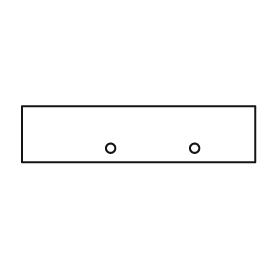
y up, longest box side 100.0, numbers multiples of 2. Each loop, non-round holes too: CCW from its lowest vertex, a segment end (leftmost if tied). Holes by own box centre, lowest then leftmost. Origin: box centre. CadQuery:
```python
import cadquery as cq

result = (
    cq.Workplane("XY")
    .moveTo(-50.0, -12.0)
    .lineTo(50.0, -12.0)
    .lineTo(50.0, 12.0)
    .lineTo(-50.0, 12.0)
    .close()
    .moveTo(-12.0, -6.0)
    .circle(2.0)
    .moveTo(24.0, -6.0)
    .circle(2.0)
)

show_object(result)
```